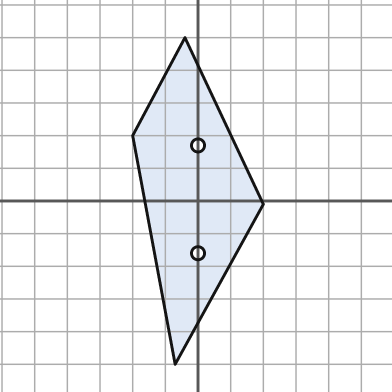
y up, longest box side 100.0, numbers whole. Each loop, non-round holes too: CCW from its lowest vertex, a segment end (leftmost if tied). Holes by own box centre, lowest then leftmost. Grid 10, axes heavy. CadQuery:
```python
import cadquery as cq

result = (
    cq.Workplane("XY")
    .moveTo(-7.0, -50.0)
    .lineTo(20.0, -1.0)
    .lineTo(-4.0, 50.0)
    .lineTo(-20.0, 20.0)
    .close()
    .moveTo(0.0, -16.0)
    .circle(2.0)
    .moveTo(0.0, 17.0)
    .circle(2.0)
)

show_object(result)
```